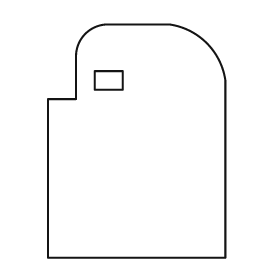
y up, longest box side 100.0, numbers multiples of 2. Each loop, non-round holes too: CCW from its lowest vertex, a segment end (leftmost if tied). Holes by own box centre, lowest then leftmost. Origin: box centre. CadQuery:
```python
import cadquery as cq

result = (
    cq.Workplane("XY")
    .moveTo(-38.0, -50.0)
    .lineTo(38.0, -50.0)
    .lineTo(38.0, 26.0)
    .threePointArc((30.0, 42.0), (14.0, 50.0))
    .lineTo(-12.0, 50.0)
    .threePointArc((-22.0, 46.0), (-26.0, 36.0))
    .lineTo(-26.0, 18.0)
    .lineTo(-38.0, 18.0)
    .close()
    .moveTo(-18.0, 22.0)
    .lineTo(-6.0, 22.0)
    .lineTo(-6.0, 30.0)
    .lineTo(-18.0, 30.0)
    .close()
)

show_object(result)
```